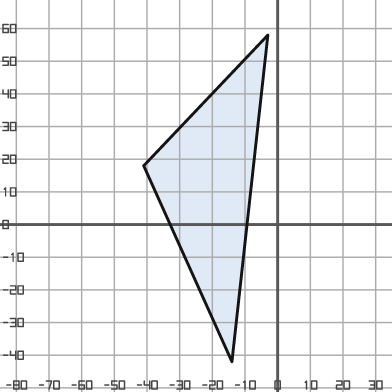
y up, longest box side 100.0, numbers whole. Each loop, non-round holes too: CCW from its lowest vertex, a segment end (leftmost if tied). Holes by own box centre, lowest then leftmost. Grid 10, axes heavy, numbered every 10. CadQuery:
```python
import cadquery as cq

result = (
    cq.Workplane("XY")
    .moveTo(-14.0, -42.0)
    .lineTo(-3.0, 58.0)
    .lineTo(-41.0, 18.0)
    .close()
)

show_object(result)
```